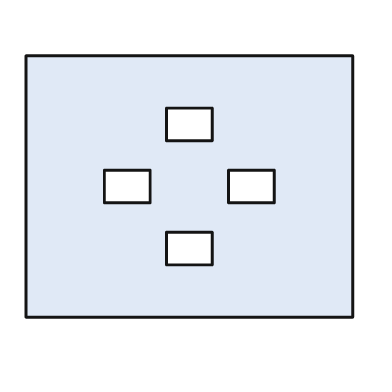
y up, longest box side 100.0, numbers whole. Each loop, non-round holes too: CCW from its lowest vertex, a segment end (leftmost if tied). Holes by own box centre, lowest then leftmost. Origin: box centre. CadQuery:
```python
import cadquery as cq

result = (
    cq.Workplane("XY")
    .moveTo(-50.0, -40.0)
    .lineTo(50.0, -40.0)
    .lineTo(50.0, 40.0)
    .lineTo(-50.0, 40.0)
    .close()
    .moveTo(-7.0, -24.0)
    .lineTo(7.0, -24.0)
    .lineTo(7.0, -14.0)
    .lineTo(-7.0, -14.0)
    .close()
    .moveTo(-26.0, -5.0)
    .lineTo(-12.0, -5.0)
    .lineTo(-12.0, 5.0)
    .lineTo(-26.0, 5.0)
    .close()
    .moveTo(12.0, -5.0)
    .lineTo(26.0, -5.0)
    .lineTo(26.0, 5.0)
    .lineTo(12.0, 5.0)
    .close()
    .moveTo(-7.0, 14.0)
    .lineTo(7.0, 14.0)
    .lineTo(7.0, 24.0)
    .lineTo(-7.0, 24.0)
    .close()
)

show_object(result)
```